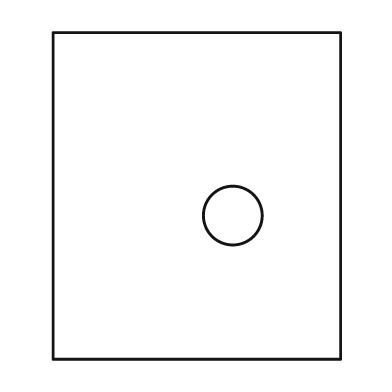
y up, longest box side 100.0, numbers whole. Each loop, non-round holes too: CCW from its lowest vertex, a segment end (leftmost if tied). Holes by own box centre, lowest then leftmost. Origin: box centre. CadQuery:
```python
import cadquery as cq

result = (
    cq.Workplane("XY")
    .moveTo(-44.0, -50.0)
    .lineTo(44.0, -50.0)
    .lineTo(44.0, 50.0)
    .lineTo(-44.0, 50.0)
    .close()
    .moveTo(11.0, -6.0)
    .circle(9.0)
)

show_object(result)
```